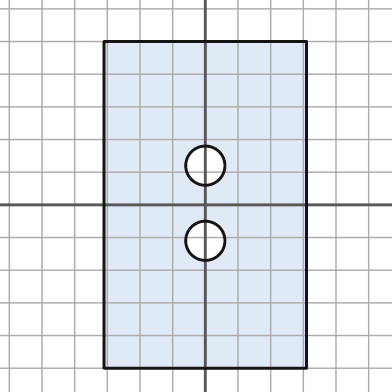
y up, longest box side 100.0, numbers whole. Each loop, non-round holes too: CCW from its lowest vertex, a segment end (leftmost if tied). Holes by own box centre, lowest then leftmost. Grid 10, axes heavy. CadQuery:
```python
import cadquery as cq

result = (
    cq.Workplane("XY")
    .moveTo(-31.0, -50.0)
    .lineTo(31.0, -50.0)
    .lineTo(31.0, 50.0)
    .lineTo(-31.0, 50.0)
    .close()
    .moveTo(0.0, -11.0)
    .circle(6.0)
    .moveTo(0.0, 12.0)
    .circle(6.0)
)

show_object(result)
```